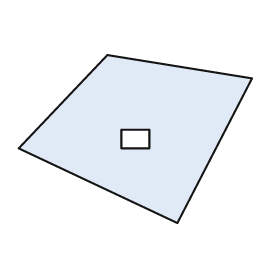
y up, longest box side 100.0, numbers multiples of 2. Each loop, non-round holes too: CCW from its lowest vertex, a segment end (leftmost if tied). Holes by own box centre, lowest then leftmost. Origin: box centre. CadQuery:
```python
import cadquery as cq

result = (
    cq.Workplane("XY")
    .moveTo(18.0, -36.0)
    .lineTo(50.0, 26.0)
    .lineTo(-12.0, 36.0)
    .lineTo(-50.0, -4.0)
    .close()
    .moveTo(-6.0, -4.0)
    .lineTo(6.0, -4.0)
    .lineTo(6.0, 4.0)
    .lineTo(-6.0, 4.0)
    .close()
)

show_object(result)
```